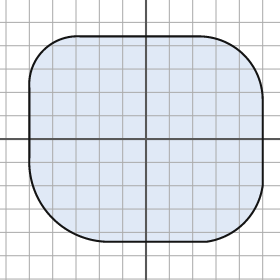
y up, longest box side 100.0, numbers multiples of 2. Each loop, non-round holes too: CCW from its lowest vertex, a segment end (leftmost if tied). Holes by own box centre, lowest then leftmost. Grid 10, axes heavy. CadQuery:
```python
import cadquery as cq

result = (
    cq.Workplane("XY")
    .moveTo(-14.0, -44.0)
    .lineTo(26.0, -44.0)
    .threePointArc((42.0, -36.0), (50.0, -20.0))
    .lineTo(50.0, 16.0)
    .threePointArc((42.0, 36.0), (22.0, 44.0))
    .lineTo(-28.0, 44.0)
    .threePointArc((-44.0, 38.0), (-50.0, 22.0))
    .lineTo(-50.0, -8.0)
    .threePointArc((-40.0, -34.0), (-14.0, -44.0))
    .close()
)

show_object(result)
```